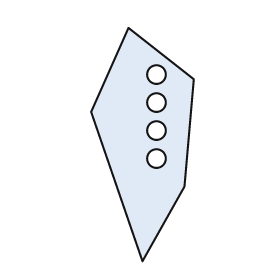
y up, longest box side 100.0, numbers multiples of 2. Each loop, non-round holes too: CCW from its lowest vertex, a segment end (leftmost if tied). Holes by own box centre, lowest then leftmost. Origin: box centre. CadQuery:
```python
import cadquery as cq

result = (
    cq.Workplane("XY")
    .moveTo(0.0, -50.0)
    .lineTo(18.0, -18.0)
    .lineTo(22.0, 28.0)
    .lineTo(-6.0, 50.0)
    .lineTo(-22.0, 14.0)
    .close()
    .moveTo(6.0, -6.0)
    .circle(4.0)
    .moveTo(6.0, 6.0)
    .circle(4.0)
    .moveTo(6.0, 18.0)
    .circle(4.0)
    .moveTo(6.0, 30.0)
    .circle(4.0)
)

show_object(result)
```